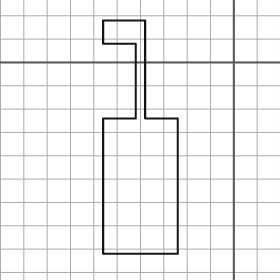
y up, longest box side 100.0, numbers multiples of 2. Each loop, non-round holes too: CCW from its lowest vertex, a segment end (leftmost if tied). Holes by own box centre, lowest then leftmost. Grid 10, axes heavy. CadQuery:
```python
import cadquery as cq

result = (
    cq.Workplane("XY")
    .moveTo(-56.0, -82.0)
    .lineTo(-24.0, -82.0)
    .lineTo(-24.0, -24.0)
    .lineTo(-38.0, -24.0)
    .lineTo(-38.0, 18.0)
    .lineTo(-56.0, 18.0)
    .lineTo(-56.0, 8.0)
    .lineTo(-42.0, 8.0)
    .lineTo(-42.0, -24.0)
    .lineTo(-56.0, -24.0)
    .close()
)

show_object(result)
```